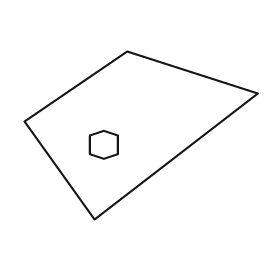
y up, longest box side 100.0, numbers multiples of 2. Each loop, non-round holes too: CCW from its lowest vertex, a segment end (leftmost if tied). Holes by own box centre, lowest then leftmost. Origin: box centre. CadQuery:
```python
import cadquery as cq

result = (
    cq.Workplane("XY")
    .moveTo(-20.0, -36.0)
    .lineTo(50.0, 18.0)
    .lineTo(-6.0, 36.0)
    .lineTo(-50.0, 6.0)
    .close()
    .moveTo(-16.0, -10.0)
    .lineTo(-10.0, -8.0)
    .lineTo(-10.0, 0.0)
    .lineTo(-16.0, 2.0)
    .lineTo(-22.0, 0.0)
    .lineTo(-22.0, -8.0)
    .close()
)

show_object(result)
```